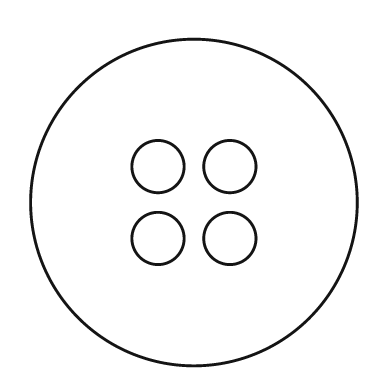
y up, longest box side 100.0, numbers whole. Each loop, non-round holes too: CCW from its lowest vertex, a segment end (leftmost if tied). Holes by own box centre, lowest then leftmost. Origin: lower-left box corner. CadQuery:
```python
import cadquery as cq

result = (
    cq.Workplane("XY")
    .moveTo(50.0, 50.0)
    .circle(50.0)
    .moveTo(39.0, 39.0)
    .circle(8.0)
    .moveTo(61.0, 39.0)
    .circle(8.0)
    .moveTo(39.0, 61.0)
    .circle(8.0)
    .moveTo(61.0, 61.0)
    .circle(8.0)
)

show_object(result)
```